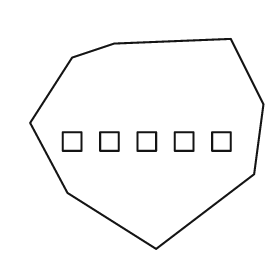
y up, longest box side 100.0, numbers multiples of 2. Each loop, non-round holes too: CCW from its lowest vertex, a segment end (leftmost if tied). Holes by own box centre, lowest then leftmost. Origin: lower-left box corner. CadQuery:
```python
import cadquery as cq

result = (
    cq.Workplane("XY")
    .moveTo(54.0, 0.0)
    .lineTo(96.0, 32.0)
    .lineTo(100.0, 62.0)
    .lineTo(86.0, 90.0)
    .lineTo(36.0, 88.0)
    .lineTo(18.0, 82.0)
    .lineTo(0.0, 54.0)
    .lineTo(16.0, 24.0)
    .close()
    .moveTo(14.0, 42.0)
    .lineTo(22.0, 42.0)
    .lineTo(22.0, 50.0)
    .lineTo(14.0, 50.0)
    .close()
    .moveTo(30.0, 42.0)
    .lineTo(38.0, 42.0)
    .lineTo(38.0, 50.0)
    .lineTo(30.0, 50.0)
    .close()
    .moveTo(46.0, 42.0)
    .lineTo(54.0, 42.0)
    .lineTo(54.0, 50.0)
    .lineTo(46.0, 50.0)
    .close()
    .moveTo(62.0, 42.0)
    .lineTo(70.0, 42.0)
    .lineTo(70.0, 50.0)
    .lineTo(62.0, 50.0)
    .close()
    .moveTo(78.0, 42.0)
    .lineTo(86.0, 42.0)
    .lineTo(86.0, 50.0)
    .lineTo(78.0, 50.0)
    .close()
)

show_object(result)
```